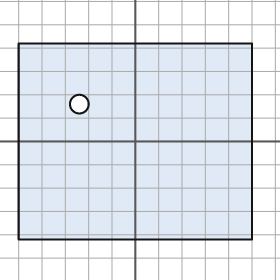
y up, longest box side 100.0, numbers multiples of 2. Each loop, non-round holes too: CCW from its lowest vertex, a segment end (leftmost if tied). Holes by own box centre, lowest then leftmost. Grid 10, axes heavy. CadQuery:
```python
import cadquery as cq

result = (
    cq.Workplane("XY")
    .moveTo(-50.0, -42.0)
    .lineTo(50.0, -42.0)
    .lineTo(50.0, 42.0)
    .lineTo(-50.0, 42.0)
    .close()
    .moveTo(-24.0, 16.0)
    .circle(4.0)
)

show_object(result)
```